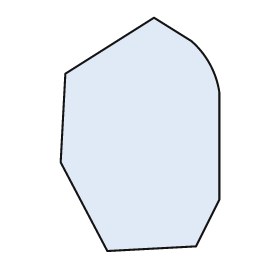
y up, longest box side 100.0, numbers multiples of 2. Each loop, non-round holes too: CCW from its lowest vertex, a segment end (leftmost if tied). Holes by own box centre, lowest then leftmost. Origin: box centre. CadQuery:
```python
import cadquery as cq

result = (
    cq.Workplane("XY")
    .moveTo(-14.0, -50.0)
    .lineTo(24.0, -48.0)
    .lineTo(34.0, -28.0)
    .lineTo(34.0, 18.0)
    .threePointArc((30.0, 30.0), (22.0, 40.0))
    .lineTo(6.0, 50.0)
    .lineTo(-32.0, 26.0)
    .lineTo(-34.0, -12.0)
    .close()
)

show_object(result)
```